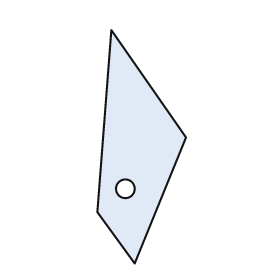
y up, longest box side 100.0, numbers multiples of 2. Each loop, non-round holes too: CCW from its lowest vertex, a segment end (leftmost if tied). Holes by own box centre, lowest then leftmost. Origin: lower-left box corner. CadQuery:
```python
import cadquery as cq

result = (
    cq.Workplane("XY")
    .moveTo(16.0, 0.0)
    .lineTo(38.0, 54.0)
    .lineTo(6.0, 100.0)
    .lineTo(0.0, 22.0)
    .close()
    .moveTo(12.0, 32.0)
    .circle(4.0)
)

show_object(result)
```